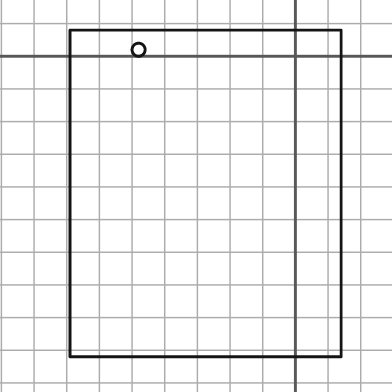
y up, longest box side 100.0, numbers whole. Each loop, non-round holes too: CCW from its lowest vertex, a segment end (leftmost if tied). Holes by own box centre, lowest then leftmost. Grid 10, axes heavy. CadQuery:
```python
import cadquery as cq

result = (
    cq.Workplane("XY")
    .moveTo(-69.0, -92.0)
    .lineTo(14.0, -92.0)
    .lineTo(14.0, 8.0)
    .lineTo(-69.0, 8.0)
    .close()
    .moveTo(-48.0, 2.0)
    .circle(2.0)
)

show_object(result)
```